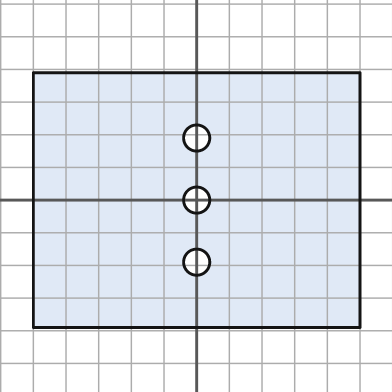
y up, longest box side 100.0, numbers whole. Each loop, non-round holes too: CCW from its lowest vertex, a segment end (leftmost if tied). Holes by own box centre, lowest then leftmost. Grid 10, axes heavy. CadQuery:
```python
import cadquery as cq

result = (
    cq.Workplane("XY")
    .moveTo(-50.0, -39.0)
    .lineTo(50.0, -39.0)
    .lineTo(50.0, 39.0)
    .lineTo(-50.0, 39.0)
    .close()
    .moveTo(0.0, -19.0)
    .circle(4.0)
    .moveTo(0.0, 0.0)
    .circle(4.0)
    .moveTo(0.0, 19.0)
    .circle(4.0)
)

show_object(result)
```